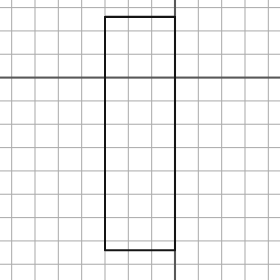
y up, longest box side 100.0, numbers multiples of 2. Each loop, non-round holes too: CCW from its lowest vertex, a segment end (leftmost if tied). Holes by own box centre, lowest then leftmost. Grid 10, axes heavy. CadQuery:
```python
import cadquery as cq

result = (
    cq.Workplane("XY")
    .moveTo(-30.0, -74.0)
    .lineTo(0.0, -74.0)
    .lineTo(0.0, 26.0)
    .lineTo(-30.0, 26.0)
    .close()
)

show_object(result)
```